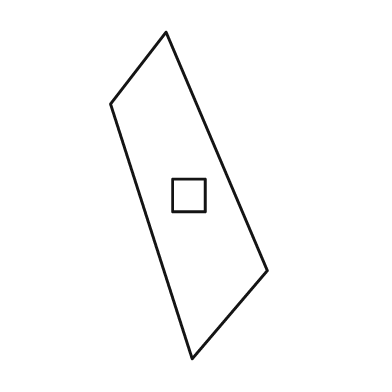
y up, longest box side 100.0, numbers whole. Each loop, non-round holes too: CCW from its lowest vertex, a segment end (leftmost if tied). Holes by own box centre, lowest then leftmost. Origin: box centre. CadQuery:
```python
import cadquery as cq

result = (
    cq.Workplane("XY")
    .moveTo(1.0, -50.0)
    .lineTo(24.0, -23.0)
    .lineTo(-7.0, 50.0)
    .lineTo(-24.0, 28.0)
    .close()
    .moveTo(-5.0, -5.0)
    .lineTo(5.0, -5.0)
    .lineTo(5.0, 5.0)
    .lineTo(-5.0, 5.0)
    .close()
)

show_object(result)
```